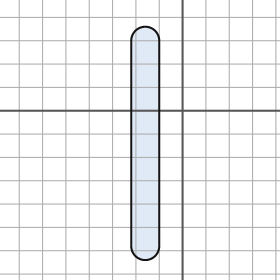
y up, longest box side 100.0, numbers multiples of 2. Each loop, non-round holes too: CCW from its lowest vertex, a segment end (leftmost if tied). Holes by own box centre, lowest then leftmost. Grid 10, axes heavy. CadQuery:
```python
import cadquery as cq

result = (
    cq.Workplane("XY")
    .moveTo(-22.0, -58.0)
    .threePointArc((-16.0, -64.0), (-10.0, -58.0))
    .lineTo(-10.0, 30.0)
    .threePointArc((-16.0, 36.0), (-22.0, 30.0))
    .close()
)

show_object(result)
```